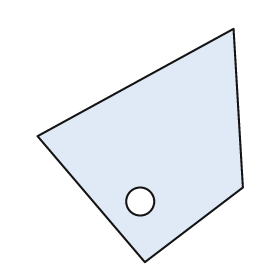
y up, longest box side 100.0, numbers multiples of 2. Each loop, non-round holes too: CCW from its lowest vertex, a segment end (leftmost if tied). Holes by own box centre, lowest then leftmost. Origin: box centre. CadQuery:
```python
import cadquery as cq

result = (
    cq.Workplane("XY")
    .moveTo(2.0, -50.0)
    .lineTo(44.0, -18.0)
    .lineTo(40.0, 50.0)
    .lineTo(-44.0, 4.0)
    .close()
    .moveTo(0.0, -24.0)
    .circle(6.0)
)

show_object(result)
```